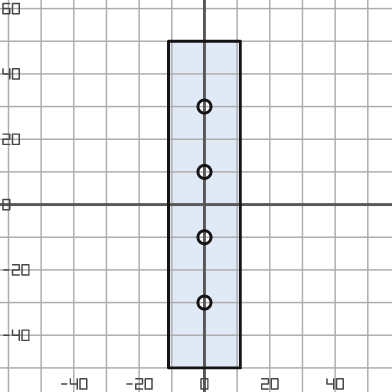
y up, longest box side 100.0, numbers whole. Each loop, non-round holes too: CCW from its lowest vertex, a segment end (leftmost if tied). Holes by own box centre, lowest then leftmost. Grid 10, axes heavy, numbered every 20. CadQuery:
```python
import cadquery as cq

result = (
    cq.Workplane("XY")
    .moveTo(-11.0, -50.0)
    .lineTo(11.0, -50.0)
    .lineTo(11.0, 50.0)
    .lineTo(-11.0, 50.0)
    .close()
    .moveTo(0.0, -30.0)
    .circle(2.0)
    .moveTo(0.0, -10.0)
    .circle(2.0)
    .moveTo(0.0, 10.0)
    .circle(2.0)
    .moveTo(0.0, 30.0)
    .circle(2.0)
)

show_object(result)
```